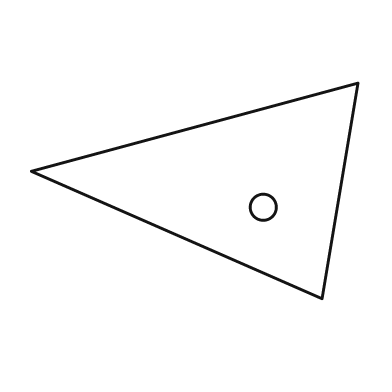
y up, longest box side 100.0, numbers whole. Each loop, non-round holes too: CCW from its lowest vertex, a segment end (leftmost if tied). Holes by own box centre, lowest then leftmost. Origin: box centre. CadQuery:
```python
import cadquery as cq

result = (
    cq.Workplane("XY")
    .moveTo(39.0, -33.0)
    .lineTo(50.0, 33.0)
    .lineTo(-50.0, 6.0)
    .close()
    .moveTo(21.0, -5.0)
    .circle(4.0)
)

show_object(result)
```